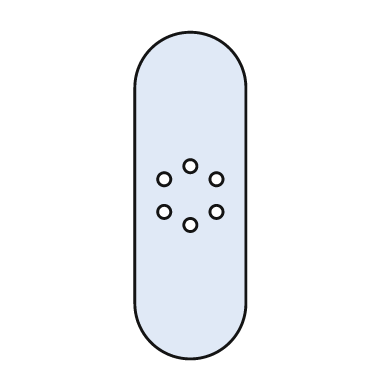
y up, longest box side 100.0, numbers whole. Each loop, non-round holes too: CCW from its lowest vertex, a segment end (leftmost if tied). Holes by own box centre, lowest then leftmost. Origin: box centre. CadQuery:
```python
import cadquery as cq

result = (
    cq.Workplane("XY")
    .moveTo(-17.0, -33.0)
    .threePointArc((0.0, -50.0), (17.0, -33.0))
    .lineTo(17.0, 33.0)
    .threePointArc((0.0, 50.0), (-17.0, 33.0))
    .close()
    .moveTo(0.0, -9.0)
    .circle(2.0)
    .moveTo(-8.0, -5.0)
    .circle(2.0)
    .moveTo(8.0, -5.0)
    .circle(2.0)
    .moveTo(-8.0, 5.0)
    .circle(2.0)
    .moveTo(8.0, 5.0)
    .circle(2.0)
    .moveTo(0.0, 9.0)
    .circle(2.0)
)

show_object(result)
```